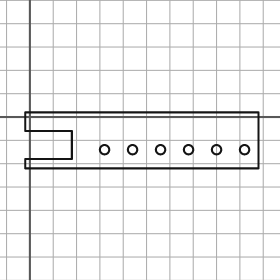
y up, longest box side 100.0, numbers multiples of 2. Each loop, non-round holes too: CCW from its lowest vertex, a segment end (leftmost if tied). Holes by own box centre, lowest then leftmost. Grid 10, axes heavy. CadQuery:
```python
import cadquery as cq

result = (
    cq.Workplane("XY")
    .moveTo(-2.0, -22.0)
    .lineTo(98.0, -22.0)
    .lineTo(98.0, 2.0)
    .lineTo(-2.0, 2.0)
    .lineTo(-2.0, -6.0)
    .lineTo(18.0, -6.0)
    .lineTo(18.0, -18.0)
    .lineTo(-2.0, -18.0)
    .close()
    .moveTo(32.0, -14.0)
    .circle(2.0)
    .moveTo(44.0, -14.0)
    .circle(2.0)
    .moveTo(56.0, -14.0)
    .circle(2.0)
    .moveTo(68.0, -14.0)
    .circle(2.0)
    .moveTo(80.0, -14.0)
    .circle(2.0)
    .moveTo(92.0, -14.0)
    .circle(2.0)
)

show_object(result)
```